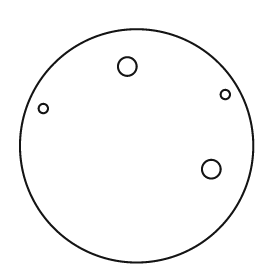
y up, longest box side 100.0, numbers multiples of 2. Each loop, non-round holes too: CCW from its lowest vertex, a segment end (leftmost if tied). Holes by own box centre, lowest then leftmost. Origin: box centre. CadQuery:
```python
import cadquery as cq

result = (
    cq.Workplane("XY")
    .moveTo(0.0, 0.0)
    .circle(50.0)
    .moveTo(32.0, -10.0)
    .circle(4.0)
    .moveTo(-40.0, 16.0)
    .circle(2.0)
    .moveTo(38.0, 22.0)
    .circle(2.0)
    .moveTo(-4.0, 34.0)
    .circle(4.0)
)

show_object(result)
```